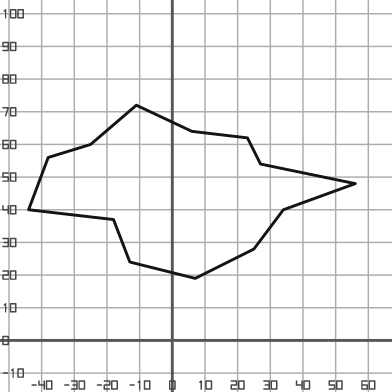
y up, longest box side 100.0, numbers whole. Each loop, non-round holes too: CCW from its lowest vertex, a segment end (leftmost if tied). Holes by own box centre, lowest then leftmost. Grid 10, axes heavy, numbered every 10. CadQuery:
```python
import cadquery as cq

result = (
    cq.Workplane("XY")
    .moveTo(7.0, 19.0)
    .lineTo(25.0, 28.0)
    .lineTo(34.0, 40.0)
    .lineTo(56.0, 48.0)
    .lineTo(27.0, 54.0)
    .lineTo(23.0, 62.0)
    .lineTo(6.0, 64.0)
    .lineTo(-11.0, 72.0)
    .lineTo(-25.0, 60.0)
    .lineTo(-38.0, 56.0)
    .lineTo(-44.0, 40.0)
    .lineTo(-18.0, 37.0)
    .lineTo(-13.0, 24.0)
    .close()
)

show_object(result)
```